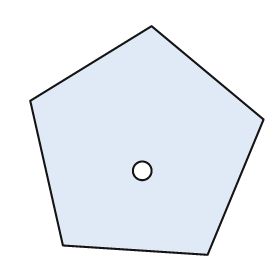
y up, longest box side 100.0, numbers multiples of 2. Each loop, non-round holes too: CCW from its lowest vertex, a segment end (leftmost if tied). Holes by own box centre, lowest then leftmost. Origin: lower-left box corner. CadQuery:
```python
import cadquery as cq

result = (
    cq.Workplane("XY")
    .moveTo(76.0, 0.0)
    .lineTo(100.0, 58.0)
    .lineTo(52.0, 98.0)
    .lineTo(0.0, 66.0)
    .lineTo(14.0, 4.0)
    .close()
    .moveTo(48.0, 36.0)
    .circle(4.0)
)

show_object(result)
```